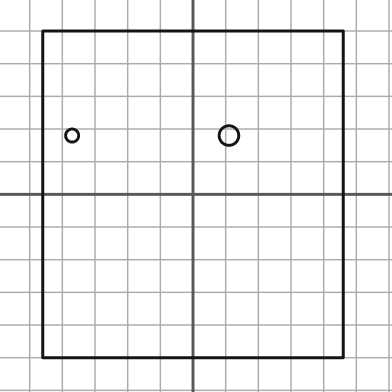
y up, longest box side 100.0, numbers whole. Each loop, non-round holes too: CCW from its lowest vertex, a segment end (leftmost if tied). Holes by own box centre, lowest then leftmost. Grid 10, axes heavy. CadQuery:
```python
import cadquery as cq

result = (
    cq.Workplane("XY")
    .moveTo(-46.0, -50.0)
    .lineTo(46.0, -50.0)
    .lineTo(46.0, 50.0)
    .lineTo(-46.0, 50.0)
    .close()
    .moveTo(-37.0, 18.0)
    .circle(2.0)
    .moveTo(11.0, 18.0)
    .circle(3.0)
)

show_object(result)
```